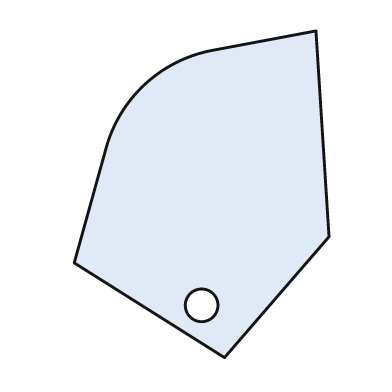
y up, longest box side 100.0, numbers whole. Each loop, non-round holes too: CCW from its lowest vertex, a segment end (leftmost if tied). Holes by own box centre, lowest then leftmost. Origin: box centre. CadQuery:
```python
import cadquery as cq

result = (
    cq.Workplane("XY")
    .moveTo(7.0, -50.0)
    .lineTo(39.0, -13.0)
    .lineTo(35.0, 50.0)
    .lineTo(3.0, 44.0)
    .threePointArc((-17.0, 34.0), (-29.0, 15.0))
    .lineTo(-39.0, -21.0)
    .close()
    .moveTo(0.0, -34.0)
    .circle(5.0)
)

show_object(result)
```